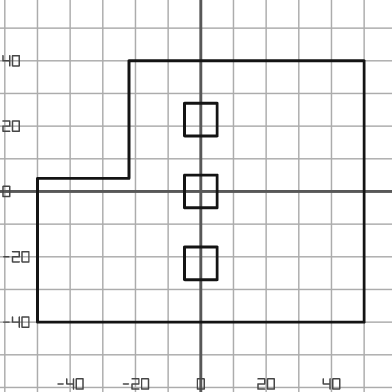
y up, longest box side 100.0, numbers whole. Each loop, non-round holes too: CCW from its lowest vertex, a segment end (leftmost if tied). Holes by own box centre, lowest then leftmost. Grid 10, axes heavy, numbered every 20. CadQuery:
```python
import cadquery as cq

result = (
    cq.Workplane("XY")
    .moveTo(-50.0, -40.0)
    .lineTo(50.0, -40.0)
    .lineTo(50.0, 40.0)
    .lineTo(-22.0, 40.0)
    .lineTo(-22.0, 4.0)
    .lineTo(-50.0, 4.0)
    .close()
    .moveTo(-5.0, -27.0)
    .lineTo(5.0, -27.0)
    .lineTo(5.0, -17.0)
    .lineTo(-5.0, -17.0)
    .close()
    .moveTo(-5.0, -5.0)
    .lineTo(5.0, -5.0)
    .lineTo(5.0, 5.0)
    .lineTo(-5.0, 5.0)
    .close()
    .moveTo(-5.0, 17.0)
    .lineTo(5.0, 17.0)
    .lineTo(5.0, 27.0)
    .lineTo(-5.0, 27.0)
    .close()
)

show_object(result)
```